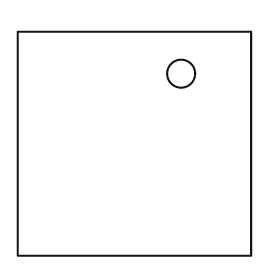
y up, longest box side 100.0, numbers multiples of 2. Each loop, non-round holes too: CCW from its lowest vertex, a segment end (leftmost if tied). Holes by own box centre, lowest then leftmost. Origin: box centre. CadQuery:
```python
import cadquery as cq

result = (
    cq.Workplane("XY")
    .moveTo(-50.0, -48.0)
    .lineTo(50.0, -48.0)
    .lineTo(50.0, 48.0)
    .lineTo(-50.0, 48.0)
    .close()
    .moveTo(20.0, 30.0)
    .circle(6.0)
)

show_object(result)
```